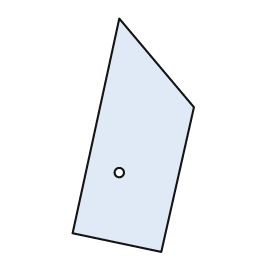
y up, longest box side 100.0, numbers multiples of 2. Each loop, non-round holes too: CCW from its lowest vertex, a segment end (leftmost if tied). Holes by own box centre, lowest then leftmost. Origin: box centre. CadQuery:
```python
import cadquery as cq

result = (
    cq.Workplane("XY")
    .moveTo(12.0, -50.0)
    .lineTo(26.0, 12.0)
    .lineTo(-6.0, 50.0)
    .lineTo(-26.0, -42.0)
    .close()
    .moveTo(-6.0, -16.0)
    .circle(2.0)
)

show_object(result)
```